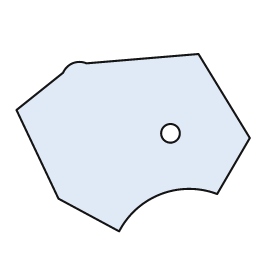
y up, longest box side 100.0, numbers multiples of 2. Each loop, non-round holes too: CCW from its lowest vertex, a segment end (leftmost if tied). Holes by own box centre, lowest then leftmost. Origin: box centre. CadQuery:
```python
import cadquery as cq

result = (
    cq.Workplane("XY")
    .moveTo(-6.0, -38.0)
    .threePointArc((12.0, -22.0), (36.0, -22.0))
    .lineTo(50.0, 2.0)
    .lineTo(28.0, 38.0)
    .lineTo(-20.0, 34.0)
    .threePointArc((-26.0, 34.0), (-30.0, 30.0))
    .lineTo(-50.0, 14.0)
    .lineTo(-32.0, -24.0)
    .close()
    .moveTo(16.0, 4.0)
    .circle(4.0)
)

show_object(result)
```